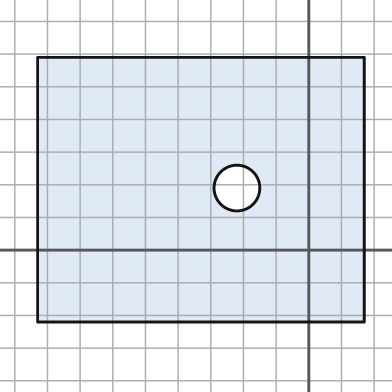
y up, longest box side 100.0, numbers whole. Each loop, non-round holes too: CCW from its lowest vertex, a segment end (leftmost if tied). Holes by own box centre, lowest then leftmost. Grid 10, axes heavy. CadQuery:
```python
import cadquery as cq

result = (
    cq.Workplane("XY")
    .moveTo(-83.0, -22.0)
    .lineTo(17.0, -22.0)
    .lineTo(17.0, 59.0)
    .lineTo(-83.0, 59.0)
    .close()
    .moveTo(-22.0, 19.0)
    .circle(7.0)
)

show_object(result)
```